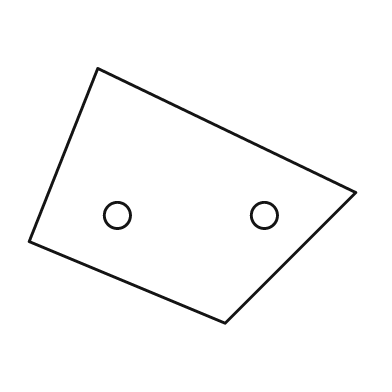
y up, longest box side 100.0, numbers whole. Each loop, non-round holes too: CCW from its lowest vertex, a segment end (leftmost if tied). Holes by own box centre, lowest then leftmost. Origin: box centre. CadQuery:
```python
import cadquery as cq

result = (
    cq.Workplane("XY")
    .moveTo(10.0, -39.0)
    .lineTo(50.0, 1.0)
    .lineTo(-29.0, 39.0)
    .lineTo(-50.0, -14.0)
    .close()
    .moveTo(-23.0, -6.0)
    .circle(4.0)
    .moveTo(22.0, -6.0)
    .circle(4.0)
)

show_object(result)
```